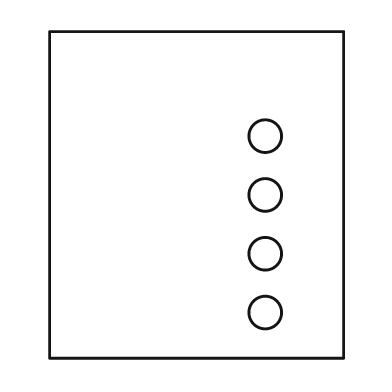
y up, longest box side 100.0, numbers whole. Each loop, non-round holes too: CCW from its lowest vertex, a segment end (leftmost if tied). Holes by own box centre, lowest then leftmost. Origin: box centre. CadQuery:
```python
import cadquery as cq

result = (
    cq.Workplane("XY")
    .moveTo(-45.0, -50.0)
    .lineTo(45.0, -50.0)
    .lineTo(45.0, 50.0)
    .lineTo(-45.0, 50.0)
    .close()
    .moveTo(21.0, -36.0)
    .circle(5.0)
    .moveTo(21.0, -18.0)
    .circle(5.0)
    .moveTo(21.0, 0.0)
    .circle(5.0)
    .moveTo(21.0, 18.0)
    .circle(5.0)
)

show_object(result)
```